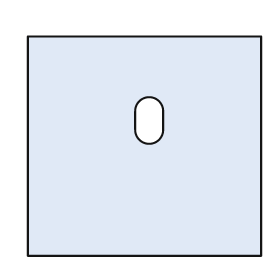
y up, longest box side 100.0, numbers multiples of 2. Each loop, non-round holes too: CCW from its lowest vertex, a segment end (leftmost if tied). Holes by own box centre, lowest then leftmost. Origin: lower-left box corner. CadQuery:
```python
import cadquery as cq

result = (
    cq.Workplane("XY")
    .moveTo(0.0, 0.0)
    .lineTo(100.0, 0.0)
    .lineTo(100.0, 94.0)
    .lineTo(0.0, 94.0)
    .close()
    .moveTo(46.0, 54.0)
    .threePointArc((52.0, 48.0), (58.0, 54.0))
    .lineTo(58.0, 62.0)
    .threePointArc((52.0, 68.0), (46.0, 62.0))
    .close()
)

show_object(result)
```